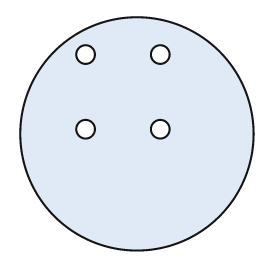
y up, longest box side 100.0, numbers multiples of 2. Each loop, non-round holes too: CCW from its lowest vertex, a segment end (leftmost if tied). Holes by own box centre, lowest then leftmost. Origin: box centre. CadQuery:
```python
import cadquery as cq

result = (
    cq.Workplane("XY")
    .moveTo(0.0, 0.0)
    .circle(50.0)
    .moveTo(-22.0, 2.0)
    .circle(4.0)
    .moveTo(10.0, 2.0)
    .circle(4.0)
    .moveTo(-22.0, 34.0)
    .circle(4.0)
    .moveTo(10.0, 34.0)
    .circle(4.0)
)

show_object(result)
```